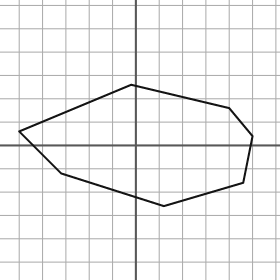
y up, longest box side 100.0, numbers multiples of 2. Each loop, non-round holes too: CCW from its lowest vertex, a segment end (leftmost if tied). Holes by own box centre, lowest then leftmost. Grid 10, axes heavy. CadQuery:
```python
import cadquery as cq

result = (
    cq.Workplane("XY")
    .moveTo(12.0, -26.0)
    .lineTo(46.0, -16.0)
    .lineTo(50.0, 4.0)
    .lineTo(40.0, 16.0)
    .lineTo(-2.0, 26.0)
    .lineTo(-50.0, 6.0)
    .lineTo(-32.0, -12.0)
    .close()
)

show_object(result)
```